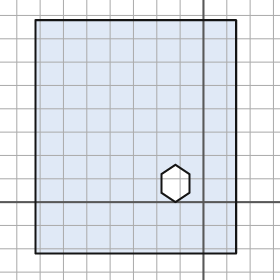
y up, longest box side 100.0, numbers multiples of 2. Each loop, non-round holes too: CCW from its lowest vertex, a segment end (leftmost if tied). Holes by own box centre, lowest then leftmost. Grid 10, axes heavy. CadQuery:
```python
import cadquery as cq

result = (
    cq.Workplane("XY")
    .moveTo(-72.0, -22.0)
    .lineTo(14.0, -22.0)
    .lineTo(14.0, 78.0)
    .lineTo(-72.0, 78.0)
    .close()
    .moveTo(-12.0, 0.0)
    .lineTo(-6.0, 4.0)
    .lineTo(-6.0, 12.0)
    .lineTo(-12.0, 16.0)
    .lineTo(-18.0, 12.0)
    .lineTo(-18.0, 4.0)
    .close()
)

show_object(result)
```